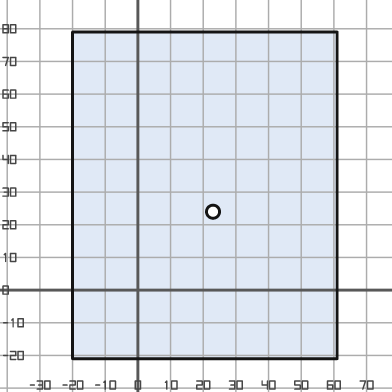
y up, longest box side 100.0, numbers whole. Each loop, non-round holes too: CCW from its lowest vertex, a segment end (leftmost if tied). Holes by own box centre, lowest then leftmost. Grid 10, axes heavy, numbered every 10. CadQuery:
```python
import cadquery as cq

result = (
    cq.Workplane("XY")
    .moveTo(-20.0, -21.0)
    .lineTo(61.0, -21.0)
    .lineTo(61.0, 79.0)
    .lineTo(-20.0, 79.0)
    .close()
    .moveTo(23.0, 24.0)
    .circle(2.0)
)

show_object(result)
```